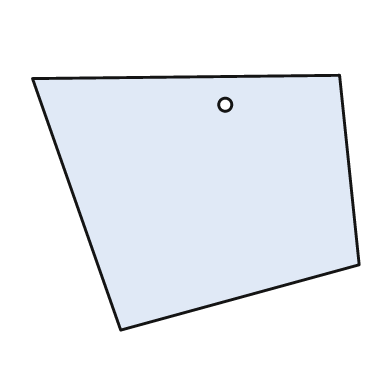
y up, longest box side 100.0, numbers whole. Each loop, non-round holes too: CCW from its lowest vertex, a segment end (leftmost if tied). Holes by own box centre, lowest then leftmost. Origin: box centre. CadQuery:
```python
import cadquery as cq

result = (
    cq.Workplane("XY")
    .moveTo(-23.0, -39.0)
    .lineTo(50.0, -19.0)
    .lineTo(44.0, 39.0)
    .lineTo(-50.0, 38.0)
    .close()
    .moveTo(9.0, 30.0)
    .circle(2.0)
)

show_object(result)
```